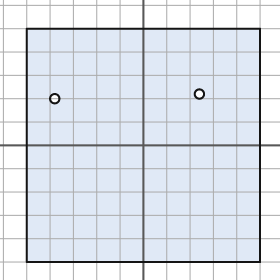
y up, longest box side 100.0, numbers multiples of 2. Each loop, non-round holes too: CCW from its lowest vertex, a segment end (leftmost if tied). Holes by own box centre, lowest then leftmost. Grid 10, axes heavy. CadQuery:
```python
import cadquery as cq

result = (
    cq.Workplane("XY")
    .moveTo(-50.0, -50.0)
    .lineTo(50.0, -50.0)
    .lineTo(50.0, 50.0)
    .lineTo(-50.0, 50.0)
    .close()
    .moveTo(-38.0, 20.0)
    .circle(2.0)
    .moveTo(24.0, 22.0)
    .circle(2.0)
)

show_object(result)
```